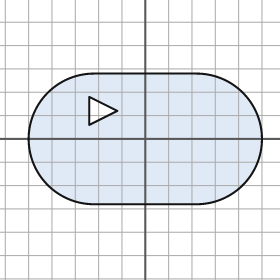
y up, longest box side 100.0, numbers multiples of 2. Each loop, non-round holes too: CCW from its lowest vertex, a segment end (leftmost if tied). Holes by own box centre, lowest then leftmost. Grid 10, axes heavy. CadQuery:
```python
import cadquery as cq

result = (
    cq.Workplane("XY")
    .moveTo(-22.0, -28.0)
    .lineTo(22.0, -28.0)
    .threePointArc((50.0, 0.0), (22.0, 28.0))
    .lineTo(-22.0, 28.0)
    .threePointArc((-50.0, 0.0), (-22.0, -28.0))
    .close()
    .moveTo(-24.0, 6.0)
    .lineTo(-12.0, 12.0)
    .lineTo(-24.0, 18.0)
    .close()
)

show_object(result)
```